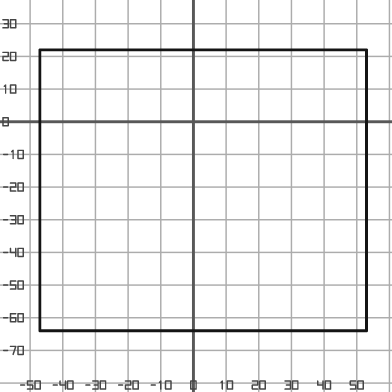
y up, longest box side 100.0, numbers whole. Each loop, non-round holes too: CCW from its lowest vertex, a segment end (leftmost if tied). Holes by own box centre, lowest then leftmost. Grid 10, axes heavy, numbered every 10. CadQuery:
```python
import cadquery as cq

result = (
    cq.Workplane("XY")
    .moveTo(-47.0, -64.0)
    .lineTo(53.0, -64.0)
    .lineTo(53.0, 22.0)
    .lineTo(-47.0, 22.0)
    .close()
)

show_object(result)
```